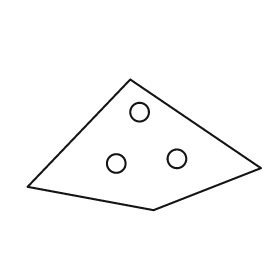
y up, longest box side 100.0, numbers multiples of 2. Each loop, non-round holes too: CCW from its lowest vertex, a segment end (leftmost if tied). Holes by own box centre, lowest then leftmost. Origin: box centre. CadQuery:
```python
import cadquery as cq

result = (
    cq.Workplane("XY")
    .moveTo(4.0, -28.0)
    .lineTo(50.0, -10.0)
    .lineTo(-6.0, 28.0)
    .lineTo(-50.0, -18.0)
    .close()
    .moveTo(-12.0, -8.0)
    .circle(4.0)
    .moveTo(14.0, -6.0)
    .circle(4.0)
    .moveTo(-2.0, 14.0)
    .circle(4.0)
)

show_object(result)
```